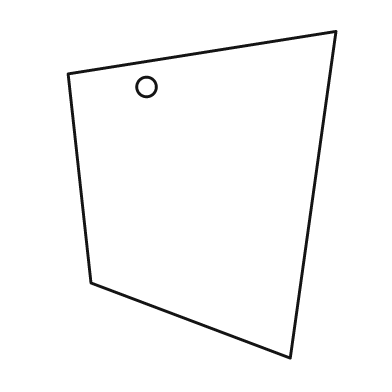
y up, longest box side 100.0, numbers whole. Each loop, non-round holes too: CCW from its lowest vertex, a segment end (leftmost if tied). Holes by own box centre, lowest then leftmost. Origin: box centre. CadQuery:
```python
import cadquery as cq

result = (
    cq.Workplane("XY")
    .moveTo(27.0, -50.0)
    .lineTo(41.0, 50.0)
    .lineTo(-41.0, 37.0)
    .lineTo(-34.0, -27.0)
    .close()
    .moveTo(-17.0, 33.0)
    .circle(3.0)
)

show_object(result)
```